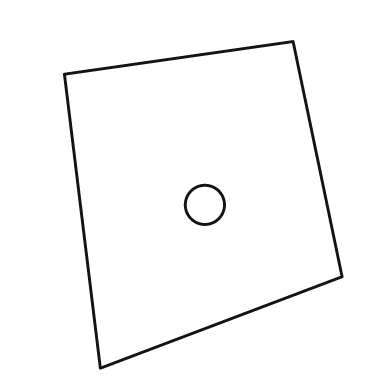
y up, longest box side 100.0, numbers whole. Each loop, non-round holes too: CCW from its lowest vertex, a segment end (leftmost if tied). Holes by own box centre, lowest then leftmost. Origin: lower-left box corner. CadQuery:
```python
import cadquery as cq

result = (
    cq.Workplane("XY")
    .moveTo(11.0, 0.0)
    .lineTo(85.0, 28.0)
    .lineTo(70.0, 100.0)
    .lineTo(0.0, 90.0)
    .close()
    .moveTo(43.0, 50.0)
    .circle(6.0)
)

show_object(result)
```